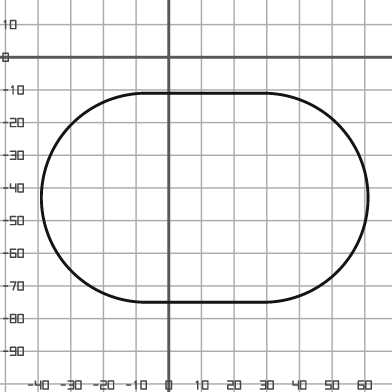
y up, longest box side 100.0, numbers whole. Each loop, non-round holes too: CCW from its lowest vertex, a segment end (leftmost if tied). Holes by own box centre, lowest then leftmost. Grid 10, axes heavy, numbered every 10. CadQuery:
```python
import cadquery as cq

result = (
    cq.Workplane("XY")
    .moveTo(-7.0, -75.0)
    .lineTo(29.0, -75.0)
    .threePointArc((61.0, -43.0), (29.0, -11.0))
    .lineTo(-7.0, -11.0)
    .threePointArc((-39.0, -43.0), (-7.0, -75.0))
    .close()
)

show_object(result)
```